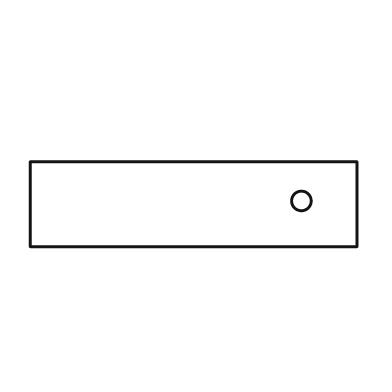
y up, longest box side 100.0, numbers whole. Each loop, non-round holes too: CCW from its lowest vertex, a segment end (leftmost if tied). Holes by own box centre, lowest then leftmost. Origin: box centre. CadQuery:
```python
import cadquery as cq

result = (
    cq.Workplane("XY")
    .moveTo(-50.0, -13.0)
    .lineTo(50.0, -13.0)
    .lineTo(50.0, 13.0)
    .lineTo(-50.0, 13.0)
    .close()
    .moveTo(33.0, 1.0)
    .circle(3.0)
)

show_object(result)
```